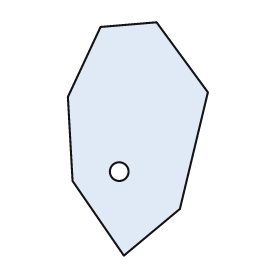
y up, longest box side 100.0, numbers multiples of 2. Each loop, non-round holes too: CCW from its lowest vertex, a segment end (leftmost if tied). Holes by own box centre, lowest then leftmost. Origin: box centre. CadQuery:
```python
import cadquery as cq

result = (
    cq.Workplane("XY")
    .moveTo(-6.0, -50.0)
    .lineTo(18.0, -30.0)
    .lineTo(30.0, 20.0)
    .lineTo(8.0, 50.0)
    .lineTo(-16.0, 48.0)
    .lineTo(-30.0, 18.0)
    .lineTo(-28.0, -18.0)
    .close()
    .moveTo(-8.0, -14.0)
    .circle(4.0)
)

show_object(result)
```